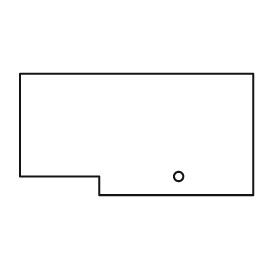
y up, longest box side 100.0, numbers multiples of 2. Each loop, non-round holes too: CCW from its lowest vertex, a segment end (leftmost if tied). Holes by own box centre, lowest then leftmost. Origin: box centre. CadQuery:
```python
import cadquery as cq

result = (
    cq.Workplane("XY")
    .moveTo(-16.0, -26.0)
    .lineTo(50.0, -26.0)
    .lineTo(50.0, 26.0)
    .lineTo(-50.0, 26.0)
    .lineTo(-50.0, -18.0)
    .lineTo(-16.0, -18.0)
    .close()
    .moveTo(18.0, -18.0)
    .circle(2.0)
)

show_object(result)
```